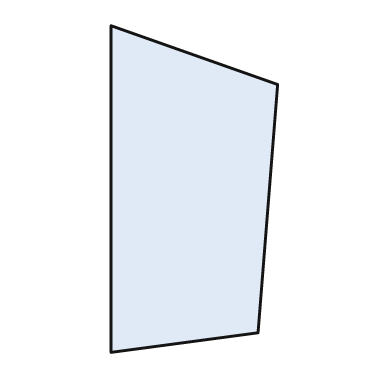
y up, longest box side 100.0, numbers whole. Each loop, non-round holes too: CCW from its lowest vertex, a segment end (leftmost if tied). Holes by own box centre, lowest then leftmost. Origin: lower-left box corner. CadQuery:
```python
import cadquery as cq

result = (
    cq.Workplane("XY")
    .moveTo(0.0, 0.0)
    .lineTo(45.0, 6.0)
    .lineTo(51.0, 82.0)
    .lineTo(0.0, 100.0)
    .close()
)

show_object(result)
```